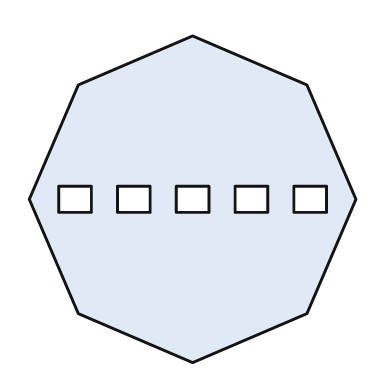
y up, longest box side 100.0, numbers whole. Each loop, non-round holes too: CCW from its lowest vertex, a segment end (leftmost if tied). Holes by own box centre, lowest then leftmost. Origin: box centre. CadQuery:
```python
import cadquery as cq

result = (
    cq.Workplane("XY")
    .moveTo(0.0, -50.0)
    .lineTo(35.0, -35.0)
    .lineTo(50.0, 0.0)
    .lineTo(35.0, 35.0)
    .lineTo(0.0, 50.0)
    .lineTo(-35.0, 35.0)
    .lineTo(-50.0, 0.0)
    .lineTo(-35.0, -35.0)
    .close()
    .moveTo(-41.0, -4.0)
    .lineTo(-31.0, -4.0)
    .lineTo(-31.0, 4.0)
    .lineTo(-41.0, 4.0)
    .close()
    .moveTo(-23.0, -4.0)
    .lineTo(-13.0, -4.0)
    .lineTo(-13.0, 4.0)
    .lineTo(-23.0, 4.0)
    .close()
    .moveTo(-5.0, -4.0)
    .lineTo(5.0, -4.0)
    .lineTo(5.0, 4.0)
    .lineTo(-5.0, 4.0)
    .close()
    .moveTo(13.0, -4.0)
    .lineTo(23.0, -4.0)
    .lineTo(23.0, 4.0)
    .lineTo(13.0, 4.0)
    .close()
    .moveTo(31.0, -4.0)
    .lineTo(41.0, -4.0)
    .lineTo(41.0, 4.0)
    .lineTo(31.0, 4.0)
    .close()
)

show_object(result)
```